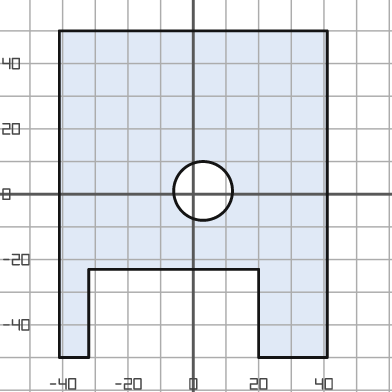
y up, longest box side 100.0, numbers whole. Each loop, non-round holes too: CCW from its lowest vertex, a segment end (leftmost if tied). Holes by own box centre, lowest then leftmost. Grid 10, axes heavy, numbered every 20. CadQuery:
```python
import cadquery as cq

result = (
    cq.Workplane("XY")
    .moveTo(-41.0, -50.0)
    .lineTo(-32.0, -50.0)
    .lineTo(-32.0, -23.0)
    .lineTo(20.0, -23.0)
    .lineTo(20.0, -50.0)
    .lineTo(41.0, -50.0)
    .lineTo(41.0, 50.0)
    .lineTo(-41.0, 50.0)
    .close()
    .moveTo(3.0, 1.0)
    .circle(9.0)
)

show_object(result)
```